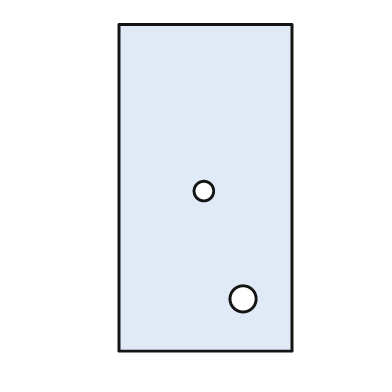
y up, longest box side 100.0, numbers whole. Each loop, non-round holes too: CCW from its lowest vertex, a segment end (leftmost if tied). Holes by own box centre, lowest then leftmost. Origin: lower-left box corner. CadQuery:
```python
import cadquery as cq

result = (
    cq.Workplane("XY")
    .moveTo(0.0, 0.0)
    .lineTo(53.0, 0.0)
    .lineTo(53.0, 100.0)
    .lineTo(0.0, 100.0)
    .close()
    .moveTo(38.0, 16.0)
    .circle(4.0)
    .moveTo(26.0, 49.0)
    .circle(3.0)
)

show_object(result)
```